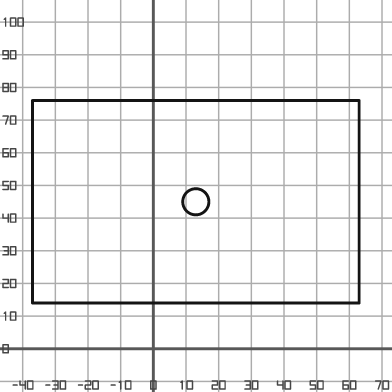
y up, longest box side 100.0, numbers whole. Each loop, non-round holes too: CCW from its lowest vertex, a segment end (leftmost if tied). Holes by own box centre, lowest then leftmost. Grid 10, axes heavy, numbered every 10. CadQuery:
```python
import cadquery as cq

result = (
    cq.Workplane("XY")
    .moveTo(-37.0, 14.0)
    .lineTo(63.0, 14.0)
    .lineTo(63.0, 76.0)
    .lineTo(-37.0, 76.0)
    .close()
    .moveTo(13.0, 45.0)
    .circle(4.0)
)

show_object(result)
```